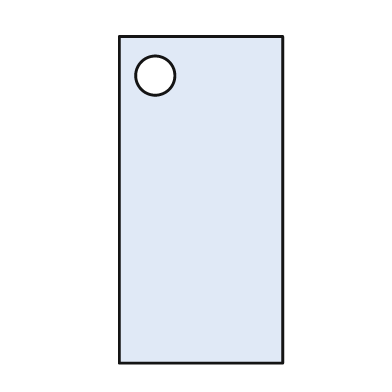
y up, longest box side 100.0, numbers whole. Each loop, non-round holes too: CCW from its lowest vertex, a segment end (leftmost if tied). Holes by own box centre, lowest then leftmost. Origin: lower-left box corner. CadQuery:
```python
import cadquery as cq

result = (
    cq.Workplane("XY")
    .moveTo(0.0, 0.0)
    .lineTo(50.0, 0.0)
    .lineTo(50.0, 100.0)
    .lineTo(0.0, 100.0)
    .close()
    .moveTo(11.0, 88.0)
    .circle(6.0)
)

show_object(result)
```